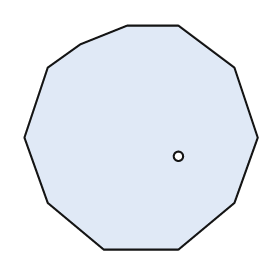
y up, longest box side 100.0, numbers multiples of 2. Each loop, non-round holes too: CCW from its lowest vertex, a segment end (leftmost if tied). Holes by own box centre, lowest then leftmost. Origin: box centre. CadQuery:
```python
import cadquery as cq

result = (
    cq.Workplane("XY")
    .moveTo(-16.0, -48.0)
    .lineTo(16.0, -48.0)
    .lineTo(40.0, -28.0)
    .lineTo(50.0, 0.0)
    .lineTo(40.0, 30.0)
    .lineTo(16.0, 48.0)
    .lineTo(-6.0, 48.0)
    .lineTo(-26.0, 40.0)
    .lineTo(-40.0, 30.0)
    .lineTo(-50.0, 0.0)
    .lineTo(-40.0, -28.0)
    .close()
    .moveTo(16.0, -8.0)
    .circle(2.0)
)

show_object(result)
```